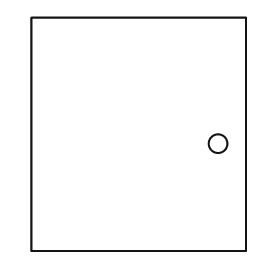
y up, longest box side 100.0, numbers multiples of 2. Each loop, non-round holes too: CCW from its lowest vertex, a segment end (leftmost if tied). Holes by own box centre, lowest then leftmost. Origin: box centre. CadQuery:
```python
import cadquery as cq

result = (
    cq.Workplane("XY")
    .moveTo(-46.0, -50.0)
    .lineTo(46.0, -50.0)
    .lineTo(46.0, 50.0)
    .lineTo(-46.0, 50.0)
    .close()
    .moveTo(34.0, -4.0)
    .circle(4.0)
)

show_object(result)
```